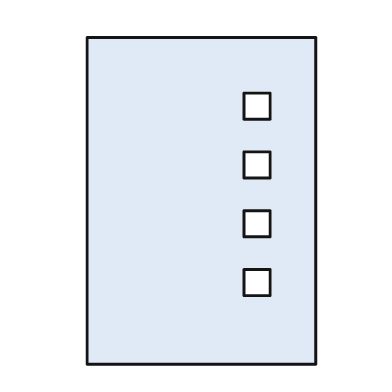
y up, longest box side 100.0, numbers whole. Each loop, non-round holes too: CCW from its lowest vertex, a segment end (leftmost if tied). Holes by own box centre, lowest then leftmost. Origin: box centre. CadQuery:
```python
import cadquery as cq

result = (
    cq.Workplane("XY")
    .moveTo(-35.0, -50.0)
    .lineTo(35.0, -50.0)
    .lineTo(35.0, 50.0)
    .lineTo(-35.0, 50.0)
    .close()
    .moveTo(13.0, -29.0)
    .lineTo(21.0, -29.0)
    .lineTo(21.0, -21.0)
    .lineTo(13.0, -21.0)
    .close()
    .moveTo(13.0, -11.0)
    .lineTo(21.0, -11.0)
    .lineTo(21.0, -3.0)
    .lineTo(13.0, -3.0)
    .close()
    .moveTo(13.0, 7.0)
    .lineTo(21.0, 7.0)
    .lineTo(21.0, 15.0)
    .lineTo(13.0, 15.0)
    .close()
    .moveTo(13.0, 25.0)
    .lineTo(21.0, 25.0)
    .lineTo(21.0, 33.0)
    .lineTo(13.0, 33.0)
    .close()
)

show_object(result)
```